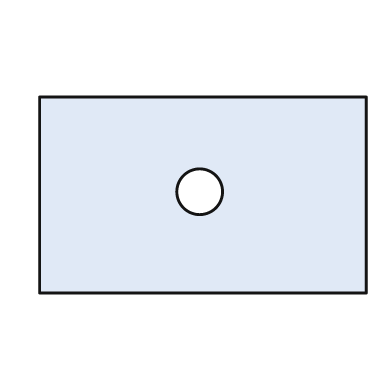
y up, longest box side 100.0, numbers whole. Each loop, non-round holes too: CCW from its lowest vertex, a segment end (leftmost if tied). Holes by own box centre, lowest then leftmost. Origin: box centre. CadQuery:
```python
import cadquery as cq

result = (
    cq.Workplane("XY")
    .moveTo(-50.0, -30.0)
    .lineTo(50.0, -30.0)
    .lineTo(50.0, 30.0)
    .lineTo(-50.0, 30.0)
    .close()
    .moveTo(-1.0, 1.0)
    .circle(7.0)
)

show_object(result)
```